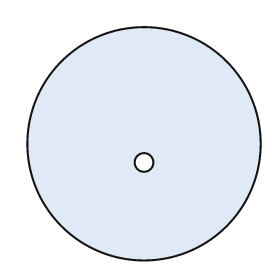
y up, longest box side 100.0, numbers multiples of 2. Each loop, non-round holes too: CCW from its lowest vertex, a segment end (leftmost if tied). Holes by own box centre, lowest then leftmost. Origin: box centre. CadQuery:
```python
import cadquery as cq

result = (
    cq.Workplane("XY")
    .moveTo(0.0, 0.0)
    .circle(50.0)
    .moveTo(0.0, -8.0)
    .circle(4.0)
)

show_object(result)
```